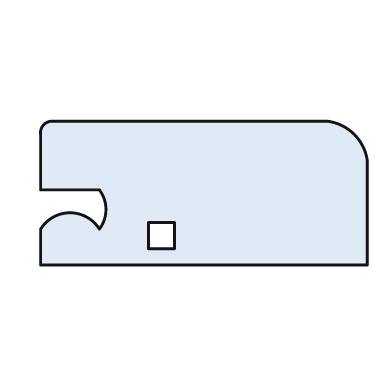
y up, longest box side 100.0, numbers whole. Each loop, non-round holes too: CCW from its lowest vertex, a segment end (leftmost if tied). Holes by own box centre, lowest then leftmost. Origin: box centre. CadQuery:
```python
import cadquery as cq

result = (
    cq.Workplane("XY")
    .moveTo(-50.0, -22.0)
    .lineTo(50.0, -22.0)
    .lineTo(50.0, 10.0)
    .threePointArc((46.0, 18.0), (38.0, 22.0))
    .lineTo(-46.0, 22.0)
    .threePointArc((-49.0, 21.0), (-50.0, 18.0))
    .lineTo(-50.0, 1.0)
    .lineTo(-32.0, 1.0)
    .threePointArc((-30.0, -5.0), (-32.0, -11.0))
    .threePointArc((-41.0, -6.0), (-50.0, -11.0))
    .close()
    .moveTo(-17.0, -17.0)
    .lineTo(-9.0, -17.0)
    .lineTo(-9.0, -9.0)
    .lineTo(-17.0, -9.0)
    .close()
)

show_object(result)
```